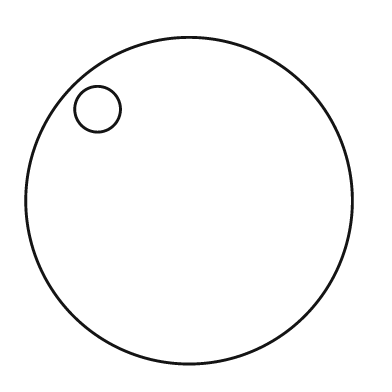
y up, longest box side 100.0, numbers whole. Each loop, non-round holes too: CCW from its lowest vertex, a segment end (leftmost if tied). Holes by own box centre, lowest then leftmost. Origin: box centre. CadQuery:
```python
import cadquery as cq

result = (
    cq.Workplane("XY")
    .moveTo(0.0, 0.0)
    .circle(50.0)
    .moveTo(-28.0, 28.0)
    .circle(7.0)
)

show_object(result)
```